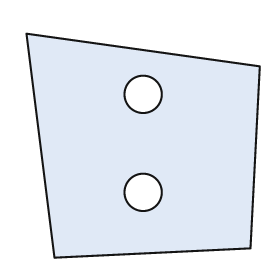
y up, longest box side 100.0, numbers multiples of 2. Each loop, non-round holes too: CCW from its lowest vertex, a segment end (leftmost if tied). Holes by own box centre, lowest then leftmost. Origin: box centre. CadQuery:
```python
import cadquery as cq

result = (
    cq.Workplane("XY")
    .moveTo(-38.0, -48.0)
    .lineTo(46.0, -44.0)
    .lineTo(50.0, 34.0)
    .lineTo(-50.0, 48.0)
    .close()
    .moveTo(0.0, -20.0)
    .circle(8.0)
    .moveTo(0.0, 22.0)
    .circle(8.0)
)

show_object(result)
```